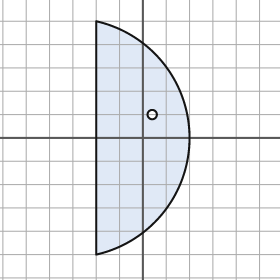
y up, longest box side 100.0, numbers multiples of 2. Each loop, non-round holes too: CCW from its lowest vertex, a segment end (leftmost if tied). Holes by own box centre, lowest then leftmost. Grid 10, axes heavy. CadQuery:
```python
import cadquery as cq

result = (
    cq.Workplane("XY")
    .moveTo(-20.0, -50.0)
    .threePointArc((20.0, 0.0), (-20.0, 50.0))
    .close()
    .moveTo(4.0, 10.0)
    .circle(2.0)
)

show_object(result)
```